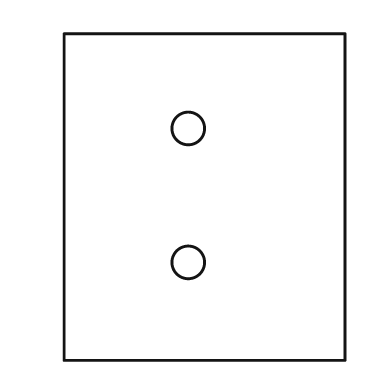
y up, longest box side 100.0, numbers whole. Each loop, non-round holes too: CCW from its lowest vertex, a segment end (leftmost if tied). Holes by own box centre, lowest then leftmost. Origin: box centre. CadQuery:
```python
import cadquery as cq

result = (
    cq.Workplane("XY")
    .moveTo(-43.0, -50.0)
    .lineTo(43.0, -50.0)
    .lineTo(43.0, 50.0)
    .lineTo(-43.0, 50.0)
    .close()
    .moveTo(-5.0, -20.0)
    .circle(5.0)
    .moveTo(-5.0, 21.0)
    .circle(5.0)
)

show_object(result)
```